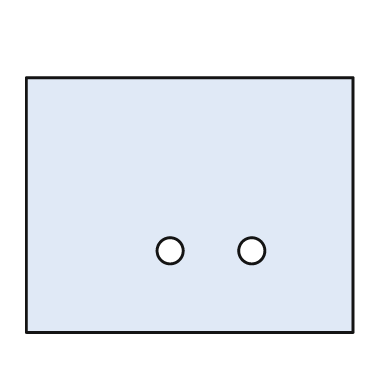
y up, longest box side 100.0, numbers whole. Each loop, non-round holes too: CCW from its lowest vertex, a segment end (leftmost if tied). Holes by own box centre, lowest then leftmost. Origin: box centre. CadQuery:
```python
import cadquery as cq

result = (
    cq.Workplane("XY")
    .moveTo(-50.0, -39.0)
    .lineTo(50.0, -39.0)
    .lineTo(50.0, 39.0)
    .lineTo(-50.0, 39.0)
    .close()
    .moveTo(-6.0, -14.0)
    .circle(4.0)
    .moveTo(19.0, -14.0)
    .circle(4.0)
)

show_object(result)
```